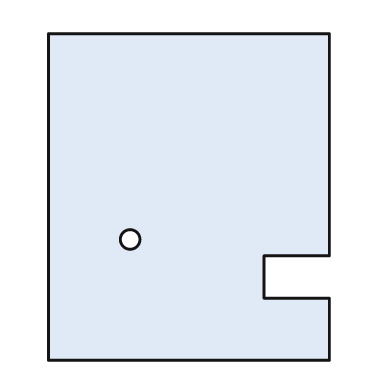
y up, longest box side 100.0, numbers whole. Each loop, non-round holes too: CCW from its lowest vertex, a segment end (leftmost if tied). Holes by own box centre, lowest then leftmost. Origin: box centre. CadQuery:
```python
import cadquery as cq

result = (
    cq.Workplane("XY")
    .moveTo(-43.0, -50.0)
    .lineTo(43.0, -50.0)
    .lineTo(43.0, -31.0)
    .lineTo(23.0, -31.0)
    .lineTo(23.0, -18.0)
    .lineTo(43.0, -18.0)
    .lineTo(43.0, 50.0)
    .lineTo(-43.0, 50.0)
    .close()
    .moveTo(-18.0, -13.0)
    .circle(3.0)
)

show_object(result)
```